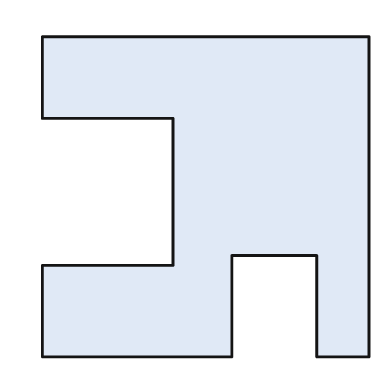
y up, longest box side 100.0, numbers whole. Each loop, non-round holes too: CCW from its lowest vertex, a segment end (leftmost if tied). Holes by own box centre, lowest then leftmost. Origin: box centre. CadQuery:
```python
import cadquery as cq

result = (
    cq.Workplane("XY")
    .moveTo(-50.0, -49.0)
    .lineTo(8.0, -49.0)
    .lineTo(8.0, -18.0)
    .lineTo(34.0, -18.0)
    .lineTo(34.0, -49.0)
    .lineTo(50.0, -49.0)
    .lineTo(50.0, 49.0)
    .lineTo(-50.0, 49.0)
    .lineTo(-50.0, 24.0)
    .lineTo(-10.0, 24.0)
    .lineTo(-10.0, -21.0)
    .lineTo(-50.0, -21.0)
    .close()
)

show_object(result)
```